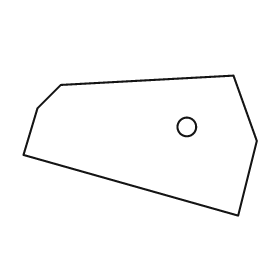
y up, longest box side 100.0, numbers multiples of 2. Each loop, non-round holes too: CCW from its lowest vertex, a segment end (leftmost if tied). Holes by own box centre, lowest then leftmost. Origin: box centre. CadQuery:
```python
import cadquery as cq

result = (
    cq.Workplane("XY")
    .moveTo(42.0, -30.0)
    .lineTo(50.0, 2.0)
    .lineTo(40.0, 30.0)
    .lineTo(-34.0, 26.0)
    .lineTo(-44.0, 16.0)
    .lineTo(-50.0, -4.0)
    .close()
    .moveTo(20.0, 8.0)
    .circle(4.0)
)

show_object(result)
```